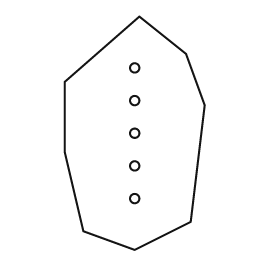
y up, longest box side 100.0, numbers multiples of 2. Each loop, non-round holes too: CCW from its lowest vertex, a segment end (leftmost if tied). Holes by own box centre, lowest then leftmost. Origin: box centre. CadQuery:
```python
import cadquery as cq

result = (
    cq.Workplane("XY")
    .moveTo(0.0, -50.0)
    .lineTo(24.0, -38.0)
    .lineTo(30.0, 12.0)
    .lineTo(22.0, 34.0)
    .lineTo(2.0, 50.0)
    .lineTo(-30.0, 22.0)
    .lineTo(-30.0, -8.0)
    .lineTo(-22.0, -42.0)
    .close()
    .moveTo(0.0, -28.0)
    .circle(2.0)
    .moveTo(0.0, -14.0)
    .circle(2.0)
    .moveTo(0.0, 0.0)
    .circle(2.0)
    .moveTo(0.0, 14.0)
    .circle(2.0)
    .moveTo(0.0, 28.0)
    .circle(2.0)
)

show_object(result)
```